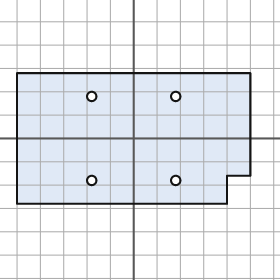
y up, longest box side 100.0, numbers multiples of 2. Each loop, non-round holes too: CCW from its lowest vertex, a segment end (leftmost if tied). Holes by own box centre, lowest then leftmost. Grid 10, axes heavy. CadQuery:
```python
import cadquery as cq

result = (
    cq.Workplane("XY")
    .moveTo(-50.0, -28.0)
    .lineTo(40.0, -28.0)
    .lineTo(40.0, -16.0)
    .lineTo(50.0, -16.0)
    .lineTo(50.0, 28.0)
    .lineTo(-50.0, 28.0)
    .close()
    .moveTo(-18.0, -18.0)
    .circle(2.0)
    .moveTo(18.0, -18.0)
    .circle(2.0)
    .moveTo(-18.0, 18.0)
    .circle(2.0)
    .moveTo(18.0, 18.0)
    .circle(2.0)
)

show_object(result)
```